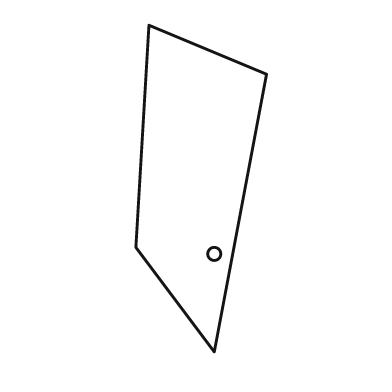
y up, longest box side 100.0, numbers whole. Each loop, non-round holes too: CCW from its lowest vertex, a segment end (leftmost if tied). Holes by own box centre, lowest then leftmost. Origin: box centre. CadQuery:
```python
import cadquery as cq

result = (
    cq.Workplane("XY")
    .moveTo(4.0, -50.0)
    .lineTo(20.0, 35.0)
    .lineTo(-16.0, 50.0)
    .lineTo(-20.0, -18.0)
    .close()
    .moveTo(4.0, -20.0)
    .circle(2.0)
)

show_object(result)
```